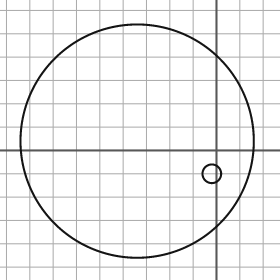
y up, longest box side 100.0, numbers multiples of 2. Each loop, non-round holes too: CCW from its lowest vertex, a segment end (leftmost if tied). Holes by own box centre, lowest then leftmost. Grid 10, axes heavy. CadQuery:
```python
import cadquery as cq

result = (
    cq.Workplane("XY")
    .moveTo(-34.0, 4.0)
    .circle(50.0)
    .moveTo(-2.0, -10.0)
    .circle(4.0)
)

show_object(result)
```